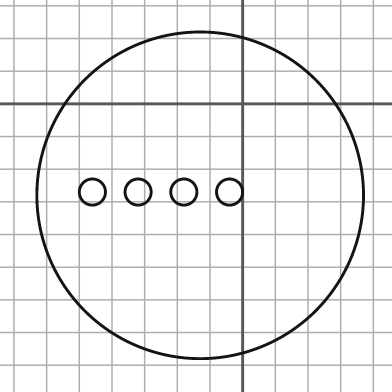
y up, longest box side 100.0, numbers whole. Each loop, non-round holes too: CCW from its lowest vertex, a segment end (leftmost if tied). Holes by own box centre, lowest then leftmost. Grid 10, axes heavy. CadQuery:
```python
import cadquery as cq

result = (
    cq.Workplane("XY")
    .moveTo(-13.0, -28.0)
    .circle(50.0)
    .moveTo(-46.0, -27.0)
    .circle(4.0)
    .moveTo(-32.0, -27.0)
    .circle(4.0)
    .moveTo(-18.0, -27.0)
    .circle(4.0)
    .moveTo(-4.0, -27.0)
    .circle(4.0)
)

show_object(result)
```